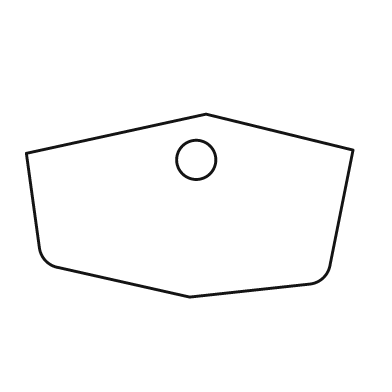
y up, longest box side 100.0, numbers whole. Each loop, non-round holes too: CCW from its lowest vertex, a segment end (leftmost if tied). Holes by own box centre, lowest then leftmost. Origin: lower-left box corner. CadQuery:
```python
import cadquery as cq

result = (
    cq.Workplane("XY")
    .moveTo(50.0, 0.0)
    .lineTo(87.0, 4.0)
    .threePointArc((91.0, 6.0), (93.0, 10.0))
    .lineTo(100.0, 45.0)
    .lineTo(55.0, 56.0)
    .lineTo(0.0, 44.0)
    .lineTo(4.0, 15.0)
    .threePointArc((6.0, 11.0), (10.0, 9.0))
    .close()
    .moveTo(52.0, 42.0)
    .circle(6.0)
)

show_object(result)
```